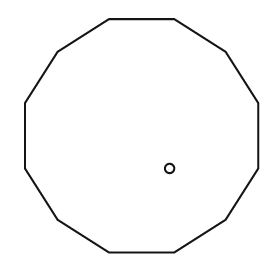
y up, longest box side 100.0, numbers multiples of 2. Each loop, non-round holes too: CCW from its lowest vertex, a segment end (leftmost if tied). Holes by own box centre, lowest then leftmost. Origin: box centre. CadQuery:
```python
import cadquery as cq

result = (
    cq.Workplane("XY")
    .moveTo(-14.0, -50.0)
    .lineTo(14.0, -50.0)
    .lineTo(36.0, -36.0)
    .lineTo(50.0, -14.0)
    .lineTo(50.0, 14.0)
    .lineTo(36.0, 36.0)
    .lineTo(14.0, 50.0)
    .lineTo(-14.0, 50.0)
    .lineTo(-36.0, 36.0)
    .lineTo(-50.0, 14.0)
    .lineTo(-50.0, -14.0)
    .lineTo(-36.0, -36.0)
    .close()
    .moveTo(12.0, -14.0)
    .circle(2.0)
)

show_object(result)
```